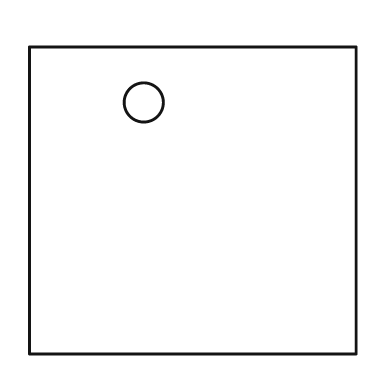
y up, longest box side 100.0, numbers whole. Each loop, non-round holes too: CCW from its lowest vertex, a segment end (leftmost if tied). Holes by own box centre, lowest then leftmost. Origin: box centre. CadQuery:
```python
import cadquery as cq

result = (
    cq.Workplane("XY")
    .moveTo(-50.0, -47.0)
    .lineTo(50.0, -47.0)
    .lineTo(50.0, 47.0)
    .lineTo(-50.0, 47.0)
    .close()
    .moveTo(-15.0, 30.0)
    .circle(6.0)
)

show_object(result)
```